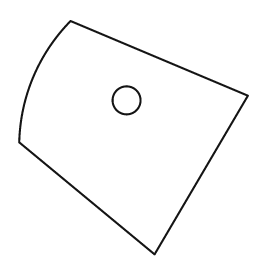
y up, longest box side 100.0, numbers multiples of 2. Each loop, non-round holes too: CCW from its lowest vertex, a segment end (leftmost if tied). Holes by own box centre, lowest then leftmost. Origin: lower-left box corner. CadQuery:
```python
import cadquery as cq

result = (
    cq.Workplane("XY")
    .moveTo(58.0, 0.0)
    .lineTo(98.0, 68.0)
    .lineTo(22.0, 100.0)
    .threePointArc((6.0, 76.0), (0.0, 48.0))
    .close()
    .moveTo(46.0, 66.0)
    .circle(6.0)
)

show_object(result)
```